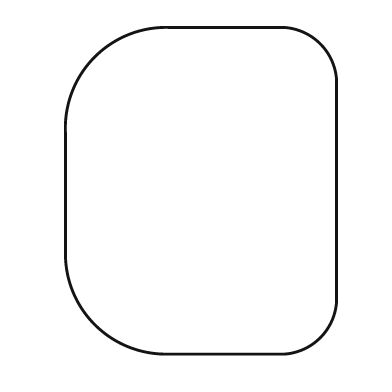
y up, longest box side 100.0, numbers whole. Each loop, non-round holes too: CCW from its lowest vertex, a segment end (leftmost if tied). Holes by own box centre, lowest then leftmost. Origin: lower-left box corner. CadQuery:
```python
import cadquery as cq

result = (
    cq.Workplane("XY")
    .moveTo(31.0, 0.0)
    .lineTo(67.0, 0.0)
    .threePointArc((78.0, 5.0), (83.0, 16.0))
    .lineTo(83.0, 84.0)
    .threePointArc((78.0, 95.0), (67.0, 100.0))
    .lineTo(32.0, 100.0)
    .threePointArc((9.0, 91.0), (0.0, 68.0))
    .lineTo(0.0, 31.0)
    .threePointArc((9.0, 9.0), (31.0, 0.0))
    .close()
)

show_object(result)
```